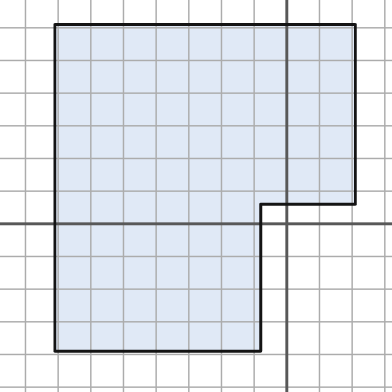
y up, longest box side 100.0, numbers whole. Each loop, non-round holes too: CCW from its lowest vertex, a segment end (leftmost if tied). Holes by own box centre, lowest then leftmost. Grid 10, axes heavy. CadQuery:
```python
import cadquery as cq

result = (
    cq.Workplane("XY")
    .moveTo(-71.0, -39.0)
    .lineTo(-8.0, -39.0)
    .lineTo(-8.0, 6.0)
    .lineTo(21.0, 6.0)
    .lineTo(21.0, 61.0)
    .lineTo(-71.0, 61.0)
    .close()
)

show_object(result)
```